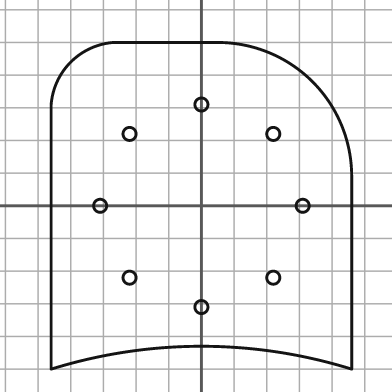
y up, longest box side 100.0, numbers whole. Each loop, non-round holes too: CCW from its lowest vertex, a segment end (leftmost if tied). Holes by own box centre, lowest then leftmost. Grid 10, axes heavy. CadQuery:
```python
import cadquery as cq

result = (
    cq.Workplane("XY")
    .moveTo(-46.0, -50.0)
    .threePointArc((0.0, -43.0), (46.0, -50.0))
    .lineTo(46.0, 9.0)
    .threePointArc((34.0, 38.0), (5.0, 50.0))
    .lineTo(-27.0, 50.0)
    .threePointArc((-40.0, 44.0), (-46.0, 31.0))
    .close()
    .moveTo(0.0, -31.0)
    .circle(2.0)
    .moveTo(-22.0, -22.0)
    .circle(2.0)
    .moveTo(22.0, -22.0)
    .circle(2.0)
    .moveTo(-31.0, 0.0)
    .circle(2.0)
    .moveTo(31.0, 0.0)
    .circle(2.0)
    .moveTo(-22.0, 22.0)
    .circle(2.0)
    .moveTo(22.0, 22.0)
    .circle(2.0)
    .moveTo(0.0, 31.0)
    .circle(2.0)
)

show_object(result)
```